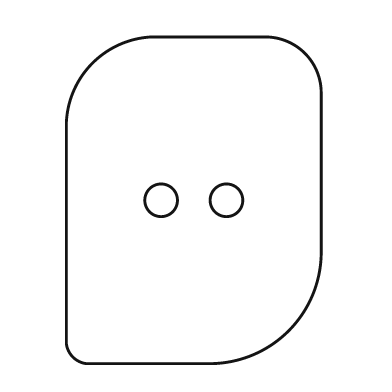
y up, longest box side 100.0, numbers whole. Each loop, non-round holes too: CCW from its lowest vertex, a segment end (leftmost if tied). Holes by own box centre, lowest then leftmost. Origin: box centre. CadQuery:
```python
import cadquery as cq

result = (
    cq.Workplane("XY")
    .moveTo(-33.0, -50.0)
    .lineTo(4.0, -50.0)
    .threePointArc((29.0, -40.0), (39.0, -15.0))
    .lineTo(39.0, 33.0)
    .threePointArc((34.0, 45.0), (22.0, 50.0))
    .lineTo(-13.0, 50.0)
    .threePointArc((-31.0, 42.0), (-39.0, 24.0))
    .lineTo(-39.0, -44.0)
    .threePointArc((-37.0, -48.0), (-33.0, -50.0))
    .close()
    .moveTo(-10.0, 0.0)
    .circle(5.0)
    .moveTo(10.0, 0.0)
    .circle(5.0)
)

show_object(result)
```